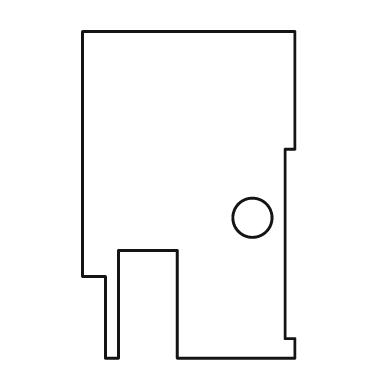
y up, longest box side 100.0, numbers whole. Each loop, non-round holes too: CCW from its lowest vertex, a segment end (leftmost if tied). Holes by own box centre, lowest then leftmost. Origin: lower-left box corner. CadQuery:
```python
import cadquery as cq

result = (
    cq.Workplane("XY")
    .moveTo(7.0, 0.0)
    .lineTo(11.0, 0.0)
    .lineTo(11.0, 33.0)
    .lineTo(29.0, 33.0)
    .lineTo(29.0, 0.0)
    .lineTo(65.0, 0.0)
    .lineTo(65.0, 6.0)
    .lineTo(62.0, 6.0)
    .lineTo(62.0, 64.0)
    .lineTo(65.0, 64.0)
    .lineTo(65.0, 100.0)
    .lineTo(0.0, 100.0)
    .lineTo(0.0, 25.0)
    .lineTo(7.0, 25.0)
    .close()
    .moveTo(52.0, 43.0)
    .circle(6.0)
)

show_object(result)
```